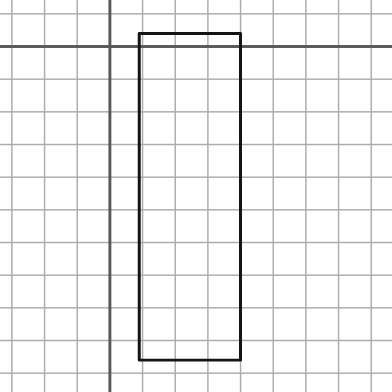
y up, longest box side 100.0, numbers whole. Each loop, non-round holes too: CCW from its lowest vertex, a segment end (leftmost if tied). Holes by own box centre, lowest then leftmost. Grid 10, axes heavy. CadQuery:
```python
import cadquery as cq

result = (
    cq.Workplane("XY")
    .moveTo(9.0, -96.0)
    .lineTo(40.0, -96.0)
    .lineTo(40.0, 4.0)
    .lineTo(9.0, 4.0)
    .close()
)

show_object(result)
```